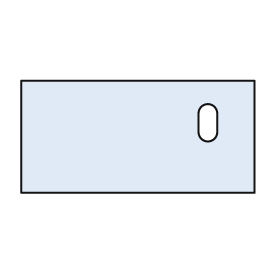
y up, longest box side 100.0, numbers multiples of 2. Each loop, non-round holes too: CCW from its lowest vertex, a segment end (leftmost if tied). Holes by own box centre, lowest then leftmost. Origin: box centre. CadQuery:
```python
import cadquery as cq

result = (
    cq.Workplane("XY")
    .moveTo(-50.0, -24.0)
    .lineTo(50.0, -24.0)
    .lineTo(50.0, 24.0)
    .lineTo(-50.0, 24.0)
    .close()
    .moveTo(26.0, 2.0)
    .threePointArc((30.0, -2.0), (34.0, 2.0))
    .lineTo(34.0, 10.0)
    .threePointArc((30.0, 14.0), (26.0, 10.0))
    .close()
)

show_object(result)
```